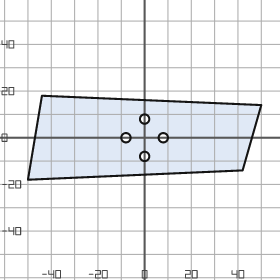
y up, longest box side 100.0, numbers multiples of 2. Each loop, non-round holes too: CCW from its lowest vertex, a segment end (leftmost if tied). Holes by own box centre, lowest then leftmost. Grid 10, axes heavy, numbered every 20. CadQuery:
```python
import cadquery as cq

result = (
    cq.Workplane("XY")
    .moveTo(-50.0, -18.0)
    .lineTo(42.0, -14.0)
    .lineTo(50.0, 14.0)
    .lineTo(-44.0, 18.0)
    .close()
    .moveTo(0.0, -8.0)
    .circle(2.0)
    .moveTo(-8.0, 0.0)
    .circle(2.0)
    .moveTo(8.0, 0.0)
    .circle(2.0)
    .moveTo(0.0, 8.0)
    .circle(2.0)
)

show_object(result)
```